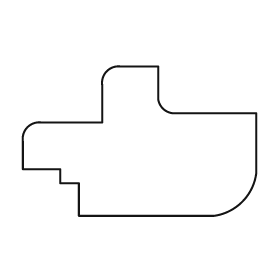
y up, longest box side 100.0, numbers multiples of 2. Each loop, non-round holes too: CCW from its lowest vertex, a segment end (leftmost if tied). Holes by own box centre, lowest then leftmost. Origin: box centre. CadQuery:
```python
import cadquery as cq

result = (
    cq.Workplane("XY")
    .moveTo(-26.0, -32.0)
    .lineTo(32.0, -32.0)
    .threePointArc((44.0, -26.0), (50.0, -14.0))
    .lineTo(50.0, 12.0)
    .lineTo(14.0, 12.0)
    .threePointArc((10.0, 14.0), (8.0, 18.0))
    .lineTo(8.0, 32.0)
    .lineTo(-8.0, 32.0)
    .threePointArc((-14.0, 30.0), (-16.0, 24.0))
    .lineTo(-16.0, 8.0)
    .lineTo(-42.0, 8.0)
    .threePointArc((-48.0, 6.0), (-50.0, 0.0))
    .lineTo(-50.0, -12.0)
    .lineTo(-34.0, -12.0)
    .lineTo(-34.0, -18.0)
    .lineTo(-26.0, -18.0)
    .close()
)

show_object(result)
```